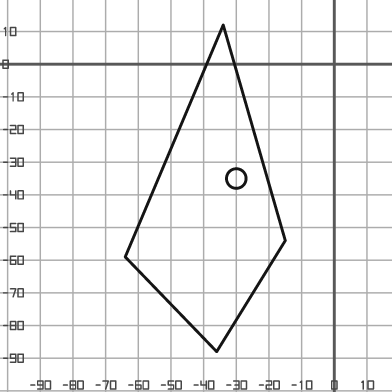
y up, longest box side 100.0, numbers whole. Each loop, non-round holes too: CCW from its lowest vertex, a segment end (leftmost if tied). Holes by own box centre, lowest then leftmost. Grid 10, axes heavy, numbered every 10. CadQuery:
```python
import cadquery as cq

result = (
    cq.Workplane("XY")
    .moveTo(-36.0, -88.0)
    .lineTo(-15.0, -54.0)
    .lineTo(-34.0, 12.0)
    .lineTo(-64.0, -59.0)
    .close()
    .moveTo(-30.0, -35.0)
    .circle(3.0)
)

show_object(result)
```